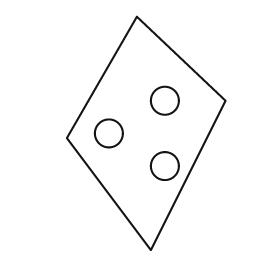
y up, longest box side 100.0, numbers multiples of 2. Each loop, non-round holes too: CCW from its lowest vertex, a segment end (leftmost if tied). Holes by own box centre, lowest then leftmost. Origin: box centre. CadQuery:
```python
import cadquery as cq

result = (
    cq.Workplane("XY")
    .moveTo(2.0, -50.0)
    .lineTo(34.0, 14.0)
    .lineTo(-4.0, 50.0)
    .lineTo(-34.0, -2.0)
    .close()
    .moveTo(8.0, -14.0)
    .circle(6.0)
    .moveTo(-16.0, 0.0)
    .circle(6.0)
    .moveTo(8.0, 14.0)
    .circle(6.0)
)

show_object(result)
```